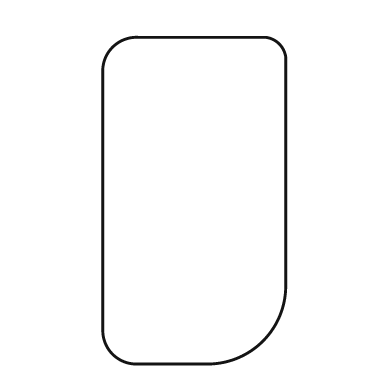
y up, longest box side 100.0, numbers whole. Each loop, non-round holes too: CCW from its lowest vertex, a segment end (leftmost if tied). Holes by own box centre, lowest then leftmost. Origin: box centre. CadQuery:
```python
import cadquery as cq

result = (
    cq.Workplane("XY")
    .moveTo(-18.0, -50.0)
    .lineTo(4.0, -50.0)
    .threePointArc((21.0, -43.0), (28.0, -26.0))
    .lineTo(28.0, 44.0)
    .threePointArc((26.0, 48.0), (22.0, 50.0))
    .lineTo(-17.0, 50.0)
    .threePointArc((-25.0, 47.0), (-28.0, 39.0))
    .lineTo(-28.0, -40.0)
    .threePointArc((-25.0, -47.0), (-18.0, -50.0))
    .close()
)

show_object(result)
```